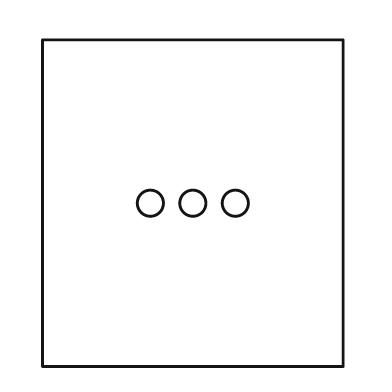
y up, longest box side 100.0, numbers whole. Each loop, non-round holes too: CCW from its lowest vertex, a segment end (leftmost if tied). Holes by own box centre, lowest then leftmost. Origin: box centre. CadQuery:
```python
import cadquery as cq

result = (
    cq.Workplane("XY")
    .moveTo(-46.0, -50.0)
    .lineTo(46.0, -50.0)
    .lineTo(46.0, 50.0)
    .lineTo(-46.0, 50.0)
    .close()
    .moveTo(-13.0, 0.0)
    .circle(4.0)
    .moveTo(0.0, 0.0)
    .circle(4.0)
    .moveTo(13.0, 0.0)
    .circle(4.0)
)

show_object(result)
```